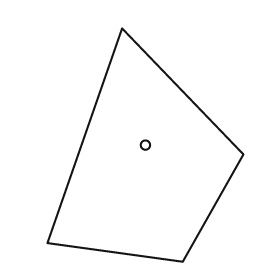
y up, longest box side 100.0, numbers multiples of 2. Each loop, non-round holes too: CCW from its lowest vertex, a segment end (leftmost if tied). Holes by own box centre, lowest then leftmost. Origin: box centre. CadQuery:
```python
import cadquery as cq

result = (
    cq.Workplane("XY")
    .moveTo(16.0, -50.0)
    .lineTo(42.0, -4.0)
    .lineTo(-10.0, 50.0)
    .lineTo(-42.0, -42.0)
    .close()
    .moveTo(0.0, 0.0)
    .circle(2.0)
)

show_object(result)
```